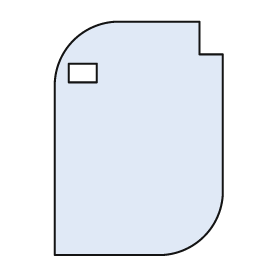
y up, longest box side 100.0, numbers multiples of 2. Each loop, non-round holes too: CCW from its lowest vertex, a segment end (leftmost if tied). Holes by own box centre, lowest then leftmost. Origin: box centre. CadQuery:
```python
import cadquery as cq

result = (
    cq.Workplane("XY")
    .moveTo(-36.0, -50.0)
    .lineTo(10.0, -50.0)
    .threePointArc((28.0, -42.0), (36.0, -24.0))
    .lineTo(36.0, 36.0)
    .lineTo(26.0, 36.0)
    .lineTo(26.0, 50.0)
    .lineTo(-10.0, 50.0)
    .threePointArc((-28.0, 42.0), (-36.0, 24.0))
    .close()
    .moveTo(-30.0, 24.0)
    .lineTo(-18.0, 24.0)
    .lineTo(-18.0, 32.0)
    .lineTo(-30.0, 32.0)
    .close()
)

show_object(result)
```